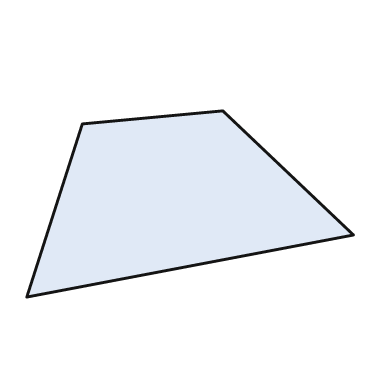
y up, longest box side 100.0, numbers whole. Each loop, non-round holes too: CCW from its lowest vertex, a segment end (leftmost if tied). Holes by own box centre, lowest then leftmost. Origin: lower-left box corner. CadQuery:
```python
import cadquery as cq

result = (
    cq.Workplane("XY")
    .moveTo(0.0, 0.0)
    .lineTo(100.0, 19.0)
    .lineTo(60.0, 57.0)
    .lineTo(17.0, 53.0)
    .close()
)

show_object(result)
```